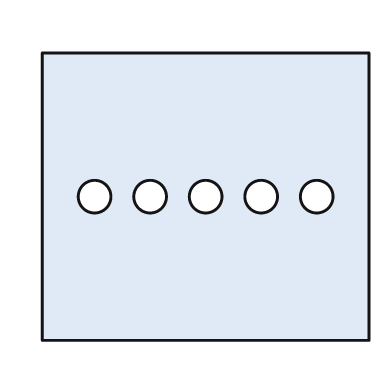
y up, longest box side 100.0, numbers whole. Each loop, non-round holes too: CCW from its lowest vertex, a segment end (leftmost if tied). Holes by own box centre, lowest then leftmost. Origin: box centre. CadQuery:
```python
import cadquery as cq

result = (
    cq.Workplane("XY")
    .moveTo(-50.0, -44.0)
    .lineTo(50.0, -44.0)
    .lineTo(50.0, 44.0)
    .lineTo(-50.0, 44.0)
    .close()
    .moveTo(-34.0, 0.0)
    .circle(5.0)
    .moveTo(-17.0, 0.0)
    .circle(5.0)
    .moveTo(0.0, 0.0)
    .circle(5.0)
    .moveTo(17.0, 0.0)
    .circle(5.0)
    .moveTo(34.0, 0.0)
    .circle(5.0)
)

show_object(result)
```